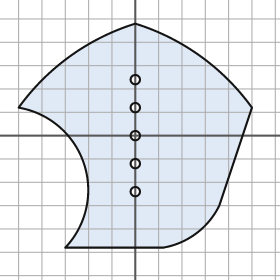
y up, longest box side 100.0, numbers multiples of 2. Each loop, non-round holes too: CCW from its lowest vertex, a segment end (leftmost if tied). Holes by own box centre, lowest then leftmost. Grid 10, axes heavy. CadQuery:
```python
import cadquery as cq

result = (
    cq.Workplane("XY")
    .moveTo(-30.0, -48.0)
    .lineTo(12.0, -48.0)
    .threePointArc((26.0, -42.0), (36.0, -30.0))
    .lineTo(50.0, 12.0)
    .threePointArc((28.0, 34.0), (0.0, 48.0))
    .threePointArc((-28.0, 34.0), (-50.0, 12.0))
    .threePointArc((-22.0, -12.0), (-30.0, -48.0))
    .close()
    .moveTo(0.0, -24.0)
    .circle(2.0)
    .moveTo(0.0, -12.0)
    .circle(2.0)
    .moveTo(0.0, 0.0)
    .circle(2.0)
    .moveTo(0.0, 12.0)
    .circle(2.0)
    .moveTo(0.0, 24.0)
    .circle(2.0)
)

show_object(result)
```